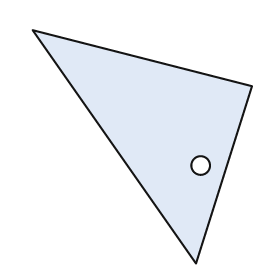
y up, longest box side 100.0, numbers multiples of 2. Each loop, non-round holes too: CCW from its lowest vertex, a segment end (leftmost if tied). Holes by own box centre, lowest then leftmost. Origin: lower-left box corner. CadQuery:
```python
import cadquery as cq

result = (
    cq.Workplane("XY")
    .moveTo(70.0, 0.0)
    .lineTo(94.0, 76.0)
    .lineTo(0.0, 100.0)
    .close()
    .moveTo(72.0, 42.0)
    .circle(4.0)
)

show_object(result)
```